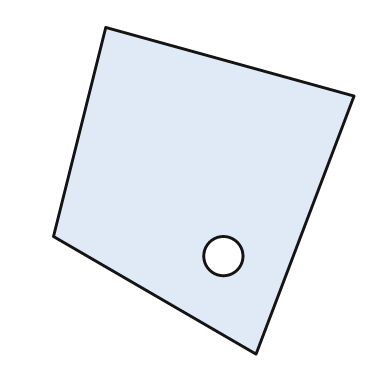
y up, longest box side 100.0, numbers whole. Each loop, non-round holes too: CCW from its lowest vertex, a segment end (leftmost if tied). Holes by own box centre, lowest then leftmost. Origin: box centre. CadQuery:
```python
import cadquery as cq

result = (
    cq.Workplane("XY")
    .moveTo(16.0, -50.0)
    .lineTo(46.0, 29.0)
    .lineTo(-30.0, 50.0)
    .lineTo(-46.0, -14.0)
    .close()
    .moveTo(6.0, -20.0)
    .circle(6.0)
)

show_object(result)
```